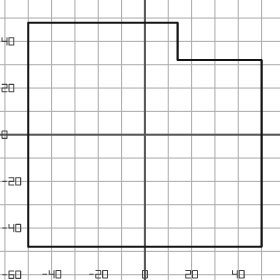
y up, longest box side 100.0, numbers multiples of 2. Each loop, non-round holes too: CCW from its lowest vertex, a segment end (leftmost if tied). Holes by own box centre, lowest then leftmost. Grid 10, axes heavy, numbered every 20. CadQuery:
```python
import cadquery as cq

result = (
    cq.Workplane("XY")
    .moveTo(-50.0, -48.0)
    .lineTo(50.0, -48.0)
    .lineTo(50.0, 32.0)
    .lineTo(14.0, 32.0)
    .lineTo(14.0, 48.0)
    .lineTo(-50.0, 48.0)
    .close()
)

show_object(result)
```